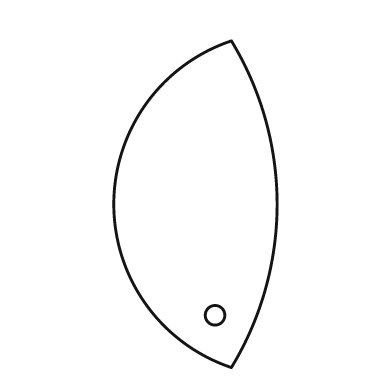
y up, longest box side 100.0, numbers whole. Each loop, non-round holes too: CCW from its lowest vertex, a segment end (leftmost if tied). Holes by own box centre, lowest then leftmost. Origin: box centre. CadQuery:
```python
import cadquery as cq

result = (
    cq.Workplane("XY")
    .moveTo(11.0, -50.0)
    .threePointArc((25.0, 0.0), (11.0, 50.0))
    .threePointArc((-25.0, 0.0), (11.0, -50.0))
    .close()
    .moveTo(6.0, -34.0)
    .circle(3.0)
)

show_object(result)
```